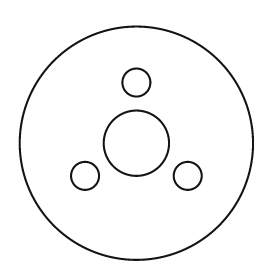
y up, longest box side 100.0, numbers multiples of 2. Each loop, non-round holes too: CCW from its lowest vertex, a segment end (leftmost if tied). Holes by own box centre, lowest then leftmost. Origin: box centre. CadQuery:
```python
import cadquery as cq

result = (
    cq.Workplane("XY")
    .moveTo(0.0, 0.0)
    .circle(50.0)
    .moveTo(-22.0, -14.0)
    .circle(6.0)
    .moveTo(22.0, -14.0)
    .circle(6.0)
    .moveTo(0.0, 0.0)
    .circle(14.0)
    .moveTo(0.0, 26.0)
    .circle(6.0)
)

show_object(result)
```